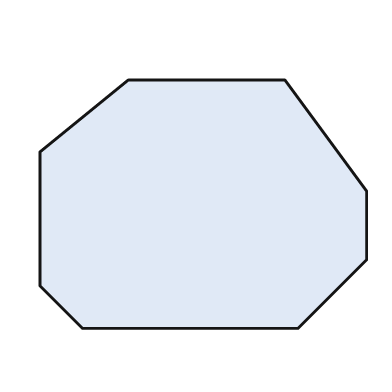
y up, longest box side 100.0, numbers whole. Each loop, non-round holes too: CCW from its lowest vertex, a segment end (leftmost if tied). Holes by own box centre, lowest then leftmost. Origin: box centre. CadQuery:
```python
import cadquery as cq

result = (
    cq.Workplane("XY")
    .moveTo(-37.0, -38.0)
    .lineTo(29.0, -38.0)
    .lineTo(50.0, -17.0)
    .lineTo(50.0, 4.0)
    .lineTo(25.0, 38.0)
    .lineTo(-23.0, 38.0)
    .lineTo(-50.0, 16.0)
    .lineTo(-50.0, -25.0)
    .close()
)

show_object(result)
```